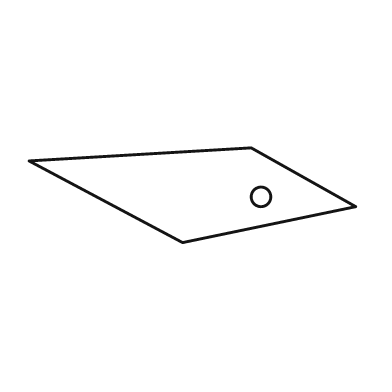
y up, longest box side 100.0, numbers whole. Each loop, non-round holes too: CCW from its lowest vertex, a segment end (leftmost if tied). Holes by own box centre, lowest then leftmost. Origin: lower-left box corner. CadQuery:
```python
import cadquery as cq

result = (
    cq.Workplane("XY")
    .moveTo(47.0, 0.0)
    .lineTo(100.0, 11.0)
    .lineTo(68.0, 29.0)
    .lineTo(0.0, 25.0)
    .close()
    .moveTo(71.0, 14.0)
    .circle(3.0)
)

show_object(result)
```